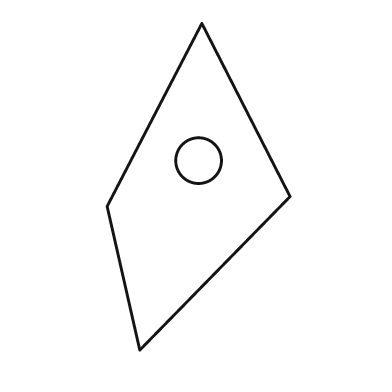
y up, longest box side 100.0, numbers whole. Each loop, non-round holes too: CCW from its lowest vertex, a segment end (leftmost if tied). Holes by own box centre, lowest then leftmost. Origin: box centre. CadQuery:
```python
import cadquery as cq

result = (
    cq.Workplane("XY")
    .moveTo(-18.0, -50.0)
    .lineTo(28.0, -3.0)
    .lineTo(1.0, 50.0)
    .lineTo(-28.0, -6.0)
    .close()
    .moveTo(0.0, 8.0)
    .circle(7.0)
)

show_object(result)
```